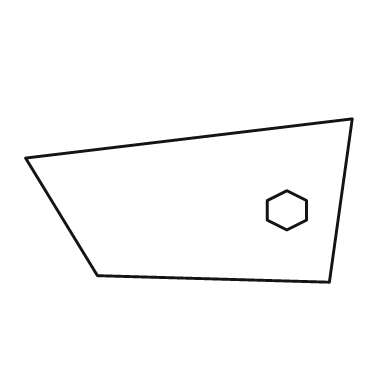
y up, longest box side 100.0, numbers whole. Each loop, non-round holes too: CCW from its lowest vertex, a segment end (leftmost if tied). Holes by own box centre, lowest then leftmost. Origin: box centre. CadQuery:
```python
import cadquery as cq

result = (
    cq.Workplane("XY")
    .moveTo(43.0, -25.0)
    .lineTo(50.0, 25.0)
    .lineTo(-50.0, 13.0)
    .lineTo(-28.0, -23.0)
    .close()
    .moveTo(30.0, -9.0)
    .lineTo(36.0, -6.0)
    .lineTo(36.0, 0.0)
    .lineTo(30.0, 3.0)
    .lineTo(24.0, 0.0)
    .lineTo(24.0, -6.0)
    .close()
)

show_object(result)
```